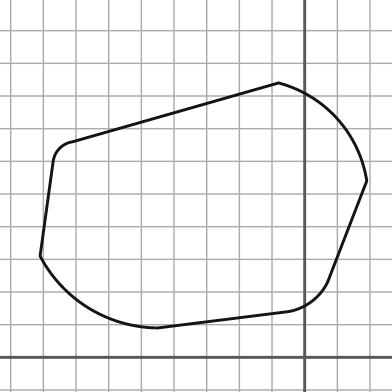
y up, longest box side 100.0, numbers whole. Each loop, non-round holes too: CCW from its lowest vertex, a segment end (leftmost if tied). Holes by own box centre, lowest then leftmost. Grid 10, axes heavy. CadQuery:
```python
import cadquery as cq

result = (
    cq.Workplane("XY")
    .moveTo(-45.0, 9.0)
    .lineTo(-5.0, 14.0)
    .threePointArc((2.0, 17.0), (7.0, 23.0))
    .lineTo(19.0, 54.0)
    .threePointArc((10.0, 73.0), (-8.0, 84.0))
    .lineTo(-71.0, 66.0)
    .threePointArc((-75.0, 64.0), (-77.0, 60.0))
    .lineTo(-81.0, 31.0)
    .threePointArc((-66.0, 15.0), (-45.0, 9.0))
    .close()
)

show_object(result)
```